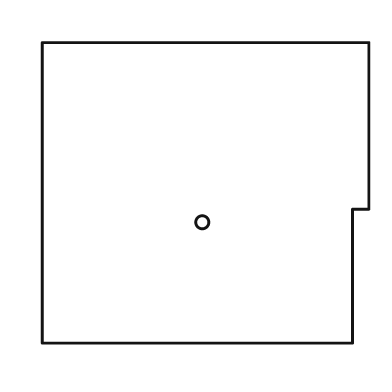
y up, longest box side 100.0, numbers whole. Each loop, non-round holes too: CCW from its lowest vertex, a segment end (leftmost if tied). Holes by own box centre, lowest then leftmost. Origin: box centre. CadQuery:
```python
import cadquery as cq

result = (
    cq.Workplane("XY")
    .moveTo(-50.0, -46.0)
    .lineTo(45.0, -46.0)
    .lineTo(45.0, -5.0)
    .lineTo(50.0, -5.0)
    .lineTo(50.0, 46.0)
    .lineTo(-50.0, 46.0)
    .close()
    .moveTo(-1.0, -9.0)
    .circle(2.0)
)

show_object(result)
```